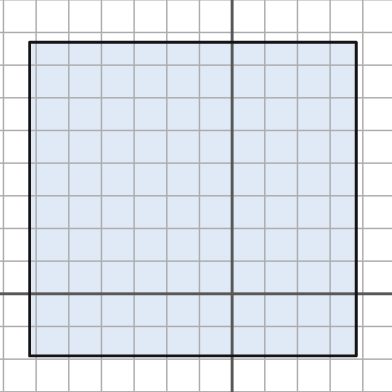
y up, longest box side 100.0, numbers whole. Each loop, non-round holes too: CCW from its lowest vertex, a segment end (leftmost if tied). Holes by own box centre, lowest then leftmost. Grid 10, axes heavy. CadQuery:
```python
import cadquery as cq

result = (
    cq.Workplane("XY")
    .moveTo(-62.0, -19.0)
    .lineTo(38.0, -19.0)
    .lineTo(38.0, 77.0)
    .lineTo(-62.0, 77.0)
    .close()
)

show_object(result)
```